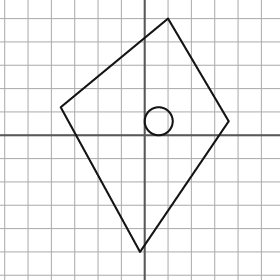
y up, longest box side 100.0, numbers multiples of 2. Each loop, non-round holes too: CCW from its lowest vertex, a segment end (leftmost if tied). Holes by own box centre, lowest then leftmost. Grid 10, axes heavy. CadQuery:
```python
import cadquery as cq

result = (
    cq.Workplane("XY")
    .moveTo(-2.0, -50.0)
    .lineTo(36.0, 6.0)
    .lineTo(10.0, 50.0)
    .lineTo(-36.0, 12.0)
    .close()
    .moveTo(6.0, 6.0)
    .circle(6.0)
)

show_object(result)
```